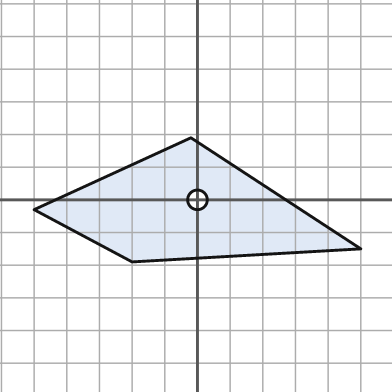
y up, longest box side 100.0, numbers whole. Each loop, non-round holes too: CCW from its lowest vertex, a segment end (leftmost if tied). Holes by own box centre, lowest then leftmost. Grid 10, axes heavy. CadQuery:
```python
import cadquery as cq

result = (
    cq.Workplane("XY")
    .moveTo(-20.0, -19.0)
    .lineTo(50.0, -15.0)
    .lineTo(-2.0, 19.0)
    .lineTo(-50.0, -3.0)
    .close()
    .moveTo(0.0, 0.0)
    .circle(3.0)
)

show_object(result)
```